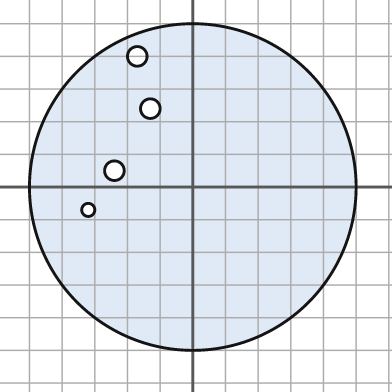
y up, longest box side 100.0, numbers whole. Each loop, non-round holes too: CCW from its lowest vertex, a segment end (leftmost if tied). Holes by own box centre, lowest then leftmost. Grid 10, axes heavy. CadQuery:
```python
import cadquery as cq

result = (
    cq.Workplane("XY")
    .moveTo(0.0, 0.0)
    .circle(50.0)
    .moveTo(-32.0, -7.0)
    .circle(2.0)
    .moveTo(-24.0, 5.0)
    .circle(3.0)
    .moveTo(-13.0, 24.0)
    .circle(3.0)
    .moveTo(-17.0, 40.0)
    .circle(3.0)
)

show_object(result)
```